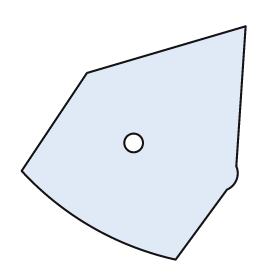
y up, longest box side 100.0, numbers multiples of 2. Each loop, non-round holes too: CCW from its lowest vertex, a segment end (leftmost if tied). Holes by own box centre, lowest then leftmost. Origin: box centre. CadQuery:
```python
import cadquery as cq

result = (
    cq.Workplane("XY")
    .moveTo(18.0, -50.0)
    .lineTo(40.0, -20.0)
    .threePointArc((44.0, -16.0), (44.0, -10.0))
    .lineTo(48.0, 50.0)
    .lineTo(-20.0, 30.0)
    .lineTo(-48.0, -12.0)
    .threePointArc((-18.0, -36.0), (18.0, -50.0))
    .close()
    .moveTo(0.0, 0.0)
    .circle(4.0)
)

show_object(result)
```